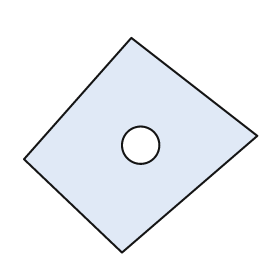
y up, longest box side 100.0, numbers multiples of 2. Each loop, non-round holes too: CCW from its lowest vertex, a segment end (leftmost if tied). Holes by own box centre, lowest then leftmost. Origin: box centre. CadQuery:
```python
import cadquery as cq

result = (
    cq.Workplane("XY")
    .moveTo(-8.0, -46.0)
    .lineTo(50.0, 4.0)
    .lineTo(-4.0, 46.0)
    .lineTo(-50.0, -6.0)
    .close()
    .moveTo(0.0, 0.0)
    .circle(8.0)
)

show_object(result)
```